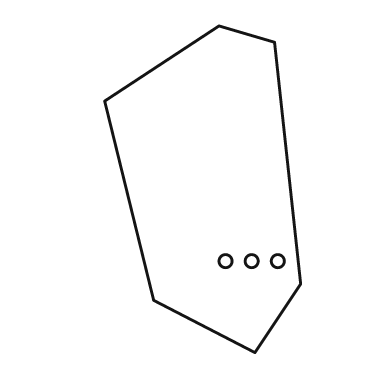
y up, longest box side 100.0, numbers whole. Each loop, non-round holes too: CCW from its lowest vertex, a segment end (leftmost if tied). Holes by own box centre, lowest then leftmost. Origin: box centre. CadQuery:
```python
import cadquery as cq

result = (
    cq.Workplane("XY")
    .moveTo(16.0, -50.0)
    .lineTo(30.0, -29.0)
    .lineTo(22.0, 45.0)
    .lineTo(5.0, 50.0)
    .lineTo(-30.0, 27.0)
    .lineTo(-15.0, -34.0)
    .close()
    .moveTo(7.0, -22.0)
    .circle(2.0)
    .moveTo(15.0, -22.0)
    .circle(2.0)
    .moveTo(23.0, -22.0)
    .circle(2.0)
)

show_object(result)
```